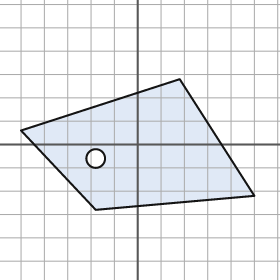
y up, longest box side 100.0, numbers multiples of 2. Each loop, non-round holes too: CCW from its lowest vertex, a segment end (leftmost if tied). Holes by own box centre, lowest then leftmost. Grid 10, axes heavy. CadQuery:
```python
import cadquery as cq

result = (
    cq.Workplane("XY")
    .moveTo(-18.0, -28.0)
    .lineTo(50.0, -22.0)
    .lineTo(18.0, 28.0)
    .lineTo(-50.0, 6.0)
    .close()
    .moveTo(-18.0, -6.0)
    .circle(4.0)
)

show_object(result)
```